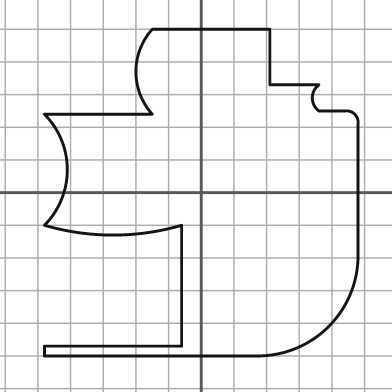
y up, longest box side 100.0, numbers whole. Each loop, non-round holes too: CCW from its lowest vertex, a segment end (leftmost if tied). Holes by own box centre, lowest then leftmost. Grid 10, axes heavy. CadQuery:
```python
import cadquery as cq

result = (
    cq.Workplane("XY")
    .moveTo(-48.0, -50.0)
    .lineTo(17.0, -50.0)
    .threePointArc((39.0, -41.0), (48.0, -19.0))
    .lineTo(48.0, 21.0)
    .threePointArc((47.0, 24.0), (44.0, 25.0))
    .lineTo(36.0, 25.0)
    .threePointArc((34.0, 29.0), (36.0, 33.0))
    .lineTo(21.0, 33.0)
    .lineTo(21.0, 50.0)
    .lineTo(-15.0, 50.0)
    .threePointArc((-20.0, 37.0), (-15.0, 24.0))
    .lineTo(-48.0, 24.0)
    .threePointArc((-41.0, 7.0), (-48.0, -10.0))
    .threePointArc((-27.0, -13.0), (-6.0, -10.0))
    .lineTo(-6.0, -47.0)
    .lineTo(-48.0, -47.0)
    .close()
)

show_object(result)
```